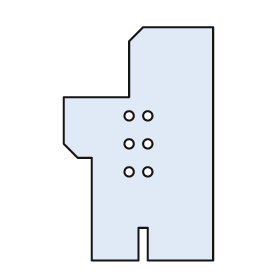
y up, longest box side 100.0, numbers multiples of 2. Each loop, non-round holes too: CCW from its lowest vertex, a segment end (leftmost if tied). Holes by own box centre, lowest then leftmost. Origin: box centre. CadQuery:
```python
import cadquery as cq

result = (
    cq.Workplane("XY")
    .moveTo(-20.0, -50.0)
    .lineTo(0.0, -50.0)
    .lineTo(0.0, -36.0)
    .lineTo(4.0, -36.0)
    .lineTo(4.0, -50.0)
    .lineTo(32.0, -50.0)
    .lineTo(32.0, 50.0)
    .lineTo(2.0, 50.0)
    .lineTo(-4.0, 44.0)
    .lineTo(-4.0, 20.0)
    .lineTo(-32.0, 20.0)
    .lineTo(-32.0, 0.0)
    .lineTo(-26.0, -6.0)
    .lineTo(-20.0, -6.0)
    .close()
    .moveTo(-4.0, -12.0)
    .circle(2.0)
    .moveTo(4.0, -12.0)
    .circle(2.0)
    .moveTo(-4.0, 0.0)
    .circle(2.0)
    .moveTo(4.0, 0.0)
    .circle(2.0)
    .moveTo(-4.0, 12.0)
    .circle(2.0)
    .moveTo(4.0, 12.0)
    .circle(2.0)
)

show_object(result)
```